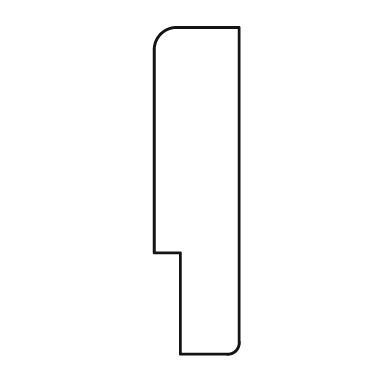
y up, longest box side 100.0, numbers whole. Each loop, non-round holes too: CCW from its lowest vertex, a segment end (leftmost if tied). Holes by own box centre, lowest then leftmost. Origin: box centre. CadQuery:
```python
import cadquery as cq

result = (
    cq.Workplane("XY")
    .moveTo(-5.0, -50.0)
    .lineTo(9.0, -50.0)
    .threePointArc((12.0, -49.0), (13.0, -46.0))
    .lineTo(13.0, 50.0)
    .lineTo(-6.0, 50.0)
    .threePointArc((-11.0, 48.0), (-13.0, 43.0))
    .lineTo(-13.0, -19.0)
    .lineTo(-5.0, -19.0)
    .close()
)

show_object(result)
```